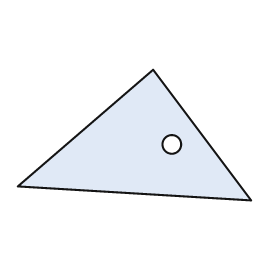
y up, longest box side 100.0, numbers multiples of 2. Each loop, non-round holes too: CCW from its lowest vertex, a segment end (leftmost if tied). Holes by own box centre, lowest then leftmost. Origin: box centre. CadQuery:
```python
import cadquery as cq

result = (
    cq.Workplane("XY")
    .moveTo(50.0, -28.0)
    .lineTo(8.0, 28.0)
    .lineTo(-50.0, -22.0)
    .close()
    .moveTo(16.0, -4.0)
    .circle(4.0)
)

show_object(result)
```